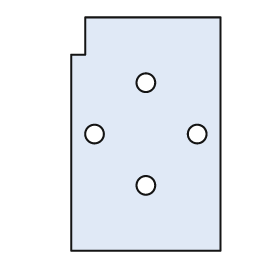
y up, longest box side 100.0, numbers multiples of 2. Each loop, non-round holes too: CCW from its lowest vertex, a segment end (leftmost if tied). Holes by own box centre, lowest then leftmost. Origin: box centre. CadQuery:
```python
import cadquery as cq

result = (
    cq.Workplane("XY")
    .moveTo(-32.0, -50.0)
    .lineTo(32.0, -50.0)
    .lineTo(32.0, 50.0)
    .lineTo(-26.0, 50.0)
    .lineTo(-26.0, 34.0)
    .lineTo(-32.0, 34.0)
    .close()
    .moveTo(0.0, -22.0)
    .circle(4.0)
    .moveTo(-22.0, 0.0)
    .circle(4.0)
    .moveTo(22.0, 0.0)
    .circle(4.0)
    .moveTo(0.0, 22.0)
    .circle(4.0)
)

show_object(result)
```